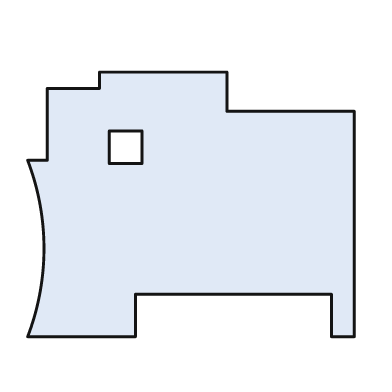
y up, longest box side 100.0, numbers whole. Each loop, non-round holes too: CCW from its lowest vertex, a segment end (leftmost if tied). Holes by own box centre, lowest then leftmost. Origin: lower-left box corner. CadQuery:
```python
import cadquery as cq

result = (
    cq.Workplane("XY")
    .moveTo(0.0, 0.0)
    .lineTo(33.0, 0.0)
    .lineTo(33.0, 13.0)
    .lineTo(93.0, 13.0)
    .lineTo(93.0, 0.0)
    .lineTo(100.0, 0.0)
    .lineTo(100.0, 69.0)
    .lineTo(61.0, 69.0)
    .lineTo(61.0, 81.0)
    .lineTo(22.0, 81.0)
    .lineTo(22.0, 76.0)
    .lineTo(6.0, 76.0)
    .lineTo(6.0, 54.0)
    .lineTo(0.0, 54.0)
    .threePointArc((5.0, 27.0), (0.0, 0.0))
    .close()
    .moveTo(25.0, 53.0)
    .lineTo(35.0, 53.0)
    .lineTo(35.0, 63.0)
    .lineTo(25.0, 63.0)
    .close()
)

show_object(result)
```